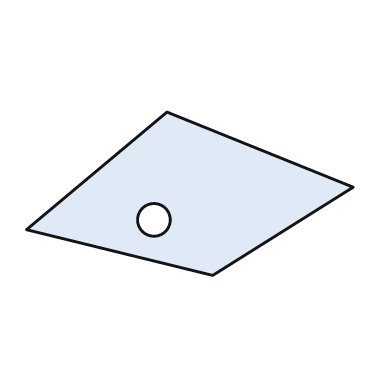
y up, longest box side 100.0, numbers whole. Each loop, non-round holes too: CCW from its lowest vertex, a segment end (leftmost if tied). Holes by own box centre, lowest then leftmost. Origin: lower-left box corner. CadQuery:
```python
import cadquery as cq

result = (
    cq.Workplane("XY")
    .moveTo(57.0, 0.0)
    .lineTo(100.0, 27.0)
    .lineTo(43.0, 50.0)
    .lineTo(0.0, 14.0)
    .close()
    .moveTo(39.0, 17.0)
    .circle(5.0)
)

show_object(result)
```